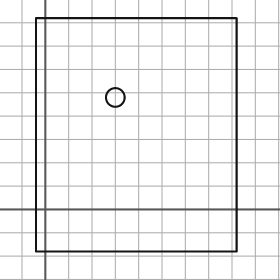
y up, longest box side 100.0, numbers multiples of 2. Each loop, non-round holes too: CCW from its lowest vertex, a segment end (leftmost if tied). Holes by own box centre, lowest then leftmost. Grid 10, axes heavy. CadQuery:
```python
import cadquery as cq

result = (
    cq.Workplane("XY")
    .moveTo(-4.0, -18.0)
    .lineTo(82.0, -18.0)
    .lineTo(82.0, 82.0)
    .lineTo(-4.0, 82.0)
    .close()
    .moveTo(30.0, 48.0)
    .circle(4.0)
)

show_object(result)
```